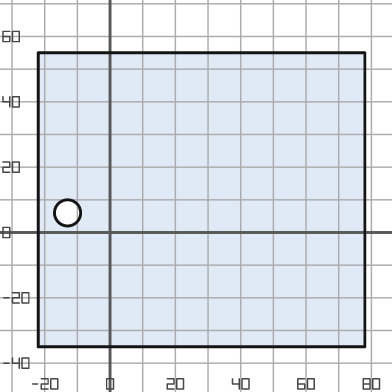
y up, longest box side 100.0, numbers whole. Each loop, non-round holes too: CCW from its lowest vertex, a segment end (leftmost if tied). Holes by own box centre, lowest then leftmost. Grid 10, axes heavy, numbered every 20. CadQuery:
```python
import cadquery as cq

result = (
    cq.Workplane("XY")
    .moveTo(-22.0, -35.0)
    .lineTo(78.0, -35.0)
    .lineTo(78.0, 55.0)
    .lineTo(-22.0, 55.0)
    .close()
    .moveTo(-13.0, 6.0)
    .circle(4.0)
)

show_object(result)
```